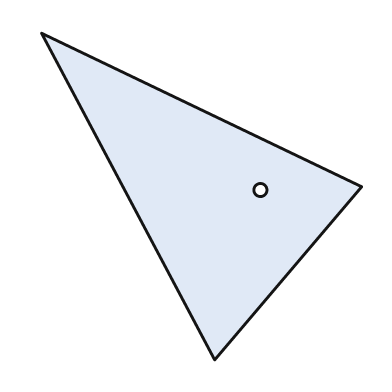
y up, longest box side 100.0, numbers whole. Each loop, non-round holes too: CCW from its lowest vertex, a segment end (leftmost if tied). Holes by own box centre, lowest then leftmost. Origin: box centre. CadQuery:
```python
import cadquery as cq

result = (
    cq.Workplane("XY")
    .moveTo(4.0, -50.0)
    .lineTo(49.0, 3.0)
    .lineTo(-49.0, 50.0)
    .close()
    .moveTo(18.0, 2.0)
    .circle(2.0)
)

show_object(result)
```